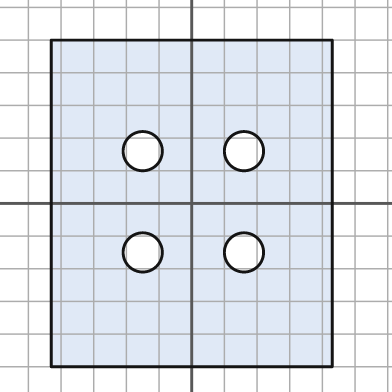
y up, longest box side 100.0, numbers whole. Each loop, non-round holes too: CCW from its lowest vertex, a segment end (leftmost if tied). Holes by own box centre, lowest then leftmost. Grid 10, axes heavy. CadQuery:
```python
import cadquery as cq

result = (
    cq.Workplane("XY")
    .moveTo(-43.0, -50.0)
    .lineTo(43.0, -50.0)
    .lineTo(43.0, 50.0)
    .lineTo(-43.0, 50.0)
    .close()
    .moveTo(-15.0, -15.0)
    .circle(6.0)
    .moveTo(16.0, -15.0)
    .circle(6.0)
    .moveTo(-15.0, 16.0)
    .circle(6.0)
    .moveTo(16.0, 16.0)
    .circle(6.0)
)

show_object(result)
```